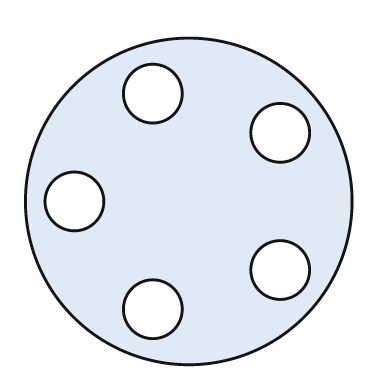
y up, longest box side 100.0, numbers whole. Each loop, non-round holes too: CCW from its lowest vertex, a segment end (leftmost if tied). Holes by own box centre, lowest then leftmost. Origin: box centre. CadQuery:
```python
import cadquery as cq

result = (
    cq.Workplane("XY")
    .moveTo(0.0, 0.0)
    .circle(50.0)
    .moveTo(-11.0, -33.0)
    .circle(9.0)
    .moveTo(28.0, -21.0)
    .circle(9.0)
    .moveTo(-35.0, 0.0)
    .circle(9.0)
    .moveTo(28.0, 21.0)
    .circle(9.0)
    .moveTo(-11.0, 33.0)
    .circle(9.0)
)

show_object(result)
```